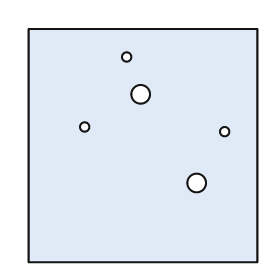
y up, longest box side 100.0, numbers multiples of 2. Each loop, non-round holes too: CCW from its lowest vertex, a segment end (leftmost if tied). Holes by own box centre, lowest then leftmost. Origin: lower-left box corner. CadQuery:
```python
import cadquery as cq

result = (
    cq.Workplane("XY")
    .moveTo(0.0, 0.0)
    .lineTo(98.0, 0.0)
    .lineTo(98.0, 100.0)
    .lineTo(0.0, 100.0)
    .close()
    .moveTo(72.0, 34.0)
    .circle(4.0)
    .moveTo(84.0, 56.0)
    .circle(2.0)
    .moveTo(24.0, 58.0)
    .circle(2.0)
    .moveTo(48.0, 72.0)
    .circle(4.0)
    .moveTo(42.0, 88.0)
    .circle(2.0)
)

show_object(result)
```